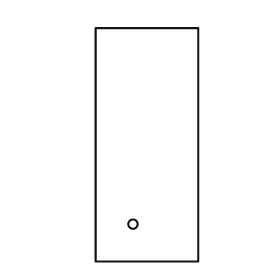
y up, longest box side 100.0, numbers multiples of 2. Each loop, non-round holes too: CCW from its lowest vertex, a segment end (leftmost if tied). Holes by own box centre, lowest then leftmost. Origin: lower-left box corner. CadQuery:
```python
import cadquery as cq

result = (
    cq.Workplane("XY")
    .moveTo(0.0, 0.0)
    .lineTo(44.0, 0.0)
    .lineTo(44.0, 100.0)
    .lineTo(0.0, 100.0)
    .close()
    .moveTo(16.0, 16.0)
    .circle(2.0)
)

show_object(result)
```